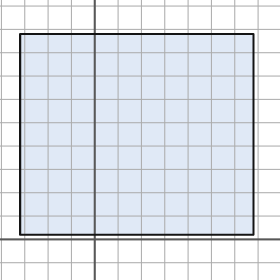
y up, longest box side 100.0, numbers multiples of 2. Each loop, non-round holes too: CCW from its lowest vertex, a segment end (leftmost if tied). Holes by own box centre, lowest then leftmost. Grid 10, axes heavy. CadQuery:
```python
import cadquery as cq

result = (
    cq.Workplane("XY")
    .moveTo(-32.0, 2.0)
    .lineTo(68.0, 2.0)
    .lineTo(68.0, 88.0)
    .lineTo(-32.0, 88.0)
    .close()
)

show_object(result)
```